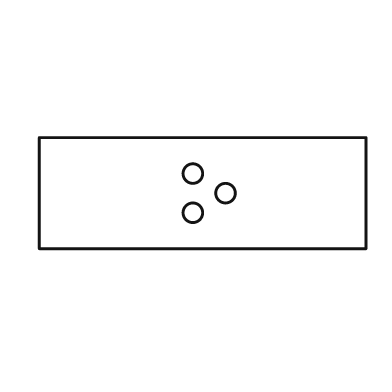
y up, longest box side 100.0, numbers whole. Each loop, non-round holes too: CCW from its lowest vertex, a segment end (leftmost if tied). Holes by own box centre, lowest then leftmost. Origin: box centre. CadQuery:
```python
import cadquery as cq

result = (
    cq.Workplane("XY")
    .moveTo(-50.0, -17.0)
    .lineTo(50.0, -17.0)
    .lineTo(50.0, 17.0)
    .lineTo(-50.0, 17.0)
    .close()
    .moveTo(-3.0, -6.0)
    .circle(3.0)
    .moveTo(7.0, 0.0)
    .circle(3.0)
    .moveTo(-3.0, 6.0)
    .circle(3.0)
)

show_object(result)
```